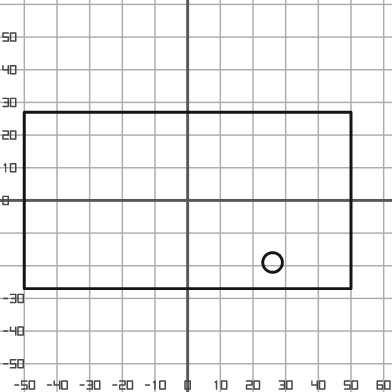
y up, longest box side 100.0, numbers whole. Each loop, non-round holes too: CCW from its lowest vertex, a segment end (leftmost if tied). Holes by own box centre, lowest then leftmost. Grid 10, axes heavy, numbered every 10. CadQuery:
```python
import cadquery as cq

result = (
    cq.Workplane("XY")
    .moveTo(-50.0, -27.0)
    .lineTo(50.0, -27.0)
    .lineTo(50.0, 27.0)
    .lineTo(-50.0, 27.0)
    .close()
    .moveTo(26.0, -19.0)
    .circle(3.0)
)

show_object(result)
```